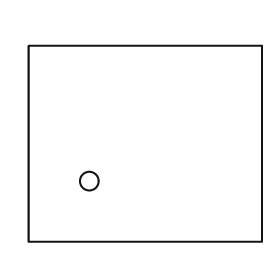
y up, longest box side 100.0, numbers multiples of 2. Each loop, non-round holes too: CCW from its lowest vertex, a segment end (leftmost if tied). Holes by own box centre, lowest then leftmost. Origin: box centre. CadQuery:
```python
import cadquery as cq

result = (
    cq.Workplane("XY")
    .moveTo(-50.0, -42.0)
    .lineTo(50.0, -42.0)
    .lineTo(50.0, 42.0)
    .lineTo(-50.0, 42.0)
    .close()
    .moveTo(-24.0, -16.0)
    .circle(4.0)
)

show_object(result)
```